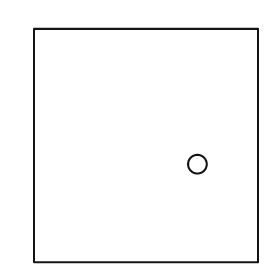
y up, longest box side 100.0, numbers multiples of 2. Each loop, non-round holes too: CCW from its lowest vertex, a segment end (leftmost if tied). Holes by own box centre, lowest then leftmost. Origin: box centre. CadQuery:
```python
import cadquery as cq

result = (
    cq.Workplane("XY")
    .moveTo(-48.0, -50.0)
    .lineTo(48.0, -50.0)
    .lineTo(48.0, 50.0)
    .lineTo(-48.0, 50.0)
    .close()
    .moveTo(22.0, -8.0)
    .circle(4.0)
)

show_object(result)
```